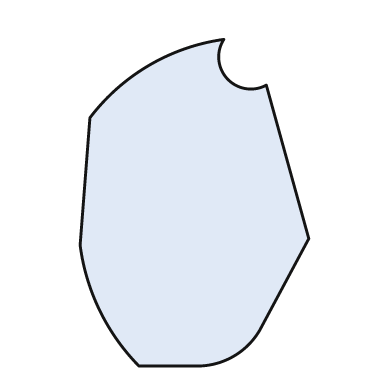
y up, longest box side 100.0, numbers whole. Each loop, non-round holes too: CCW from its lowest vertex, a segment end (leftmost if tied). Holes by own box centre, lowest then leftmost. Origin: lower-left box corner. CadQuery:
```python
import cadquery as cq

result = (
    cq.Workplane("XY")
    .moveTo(18.0, 0.0)
    .lineTo(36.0, 0.0)
    .threePointArc((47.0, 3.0), (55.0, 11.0))
    .lineTo(70.0, 39.0)
    .lineTo(57.0, 86.0)
    .threePointArc((45.0, 88.0), (44.0, 100.0))
    .threePointArc((21.0, 92.0), (3.0, 76.0))
    .lineTo(0.0, 37.0)
    .threePointArc((6.0, 17.0), (18.0, 0.0))
    .close()
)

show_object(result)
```